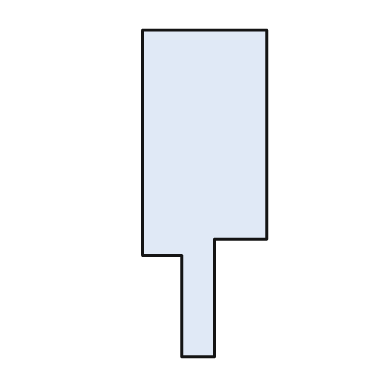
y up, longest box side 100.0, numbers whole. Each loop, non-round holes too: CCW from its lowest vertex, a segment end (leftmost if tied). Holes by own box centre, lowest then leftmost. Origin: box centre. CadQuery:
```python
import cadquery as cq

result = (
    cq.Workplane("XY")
    .moveTo(-7.0, -50.0)
    .lineTo(3.0, -50.0)
    .lineTo(3.0, -14.0)
    .lineTo(19.0, -14.0)
    .lineTo(19.0, 50.0)
    .lineTo(-19.0, 50.0)
    .lineTo(-19.0, -19.0)
    .lineTo(-7.0, -19.0)
    .close()
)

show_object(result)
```